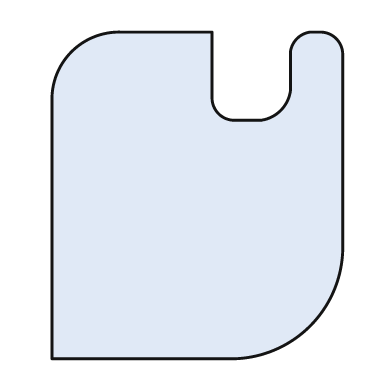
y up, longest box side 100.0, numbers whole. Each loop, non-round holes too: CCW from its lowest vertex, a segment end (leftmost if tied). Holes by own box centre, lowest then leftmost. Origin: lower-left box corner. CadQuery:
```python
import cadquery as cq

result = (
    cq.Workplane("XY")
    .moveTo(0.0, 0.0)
    .lineTo(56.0, 0.0)
    .threePointArc((79.0, 10.0), (89.0, 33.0))
    .lineTo(89.0, 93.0)
    .threePointArc((87.0, 98.0), (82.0, 100.0))
    .lineTo(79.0, 100.0)
    .threePointArc((75.0, 98.0), (73.0, 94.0))
    .lineTo(73.0, 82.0)
    .threePointArc((70.0, 76.0), (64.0, 73.0))
    .lineTo(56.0, 73.0)
    .threePointArc((51.0, 75.0), (49.0, 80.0))
    .lineTo(49.0, 100.0)
    .lineTo(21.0, 100.0)
    .threePointArc((6.0, 94.0), (0.0, 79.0))
    .close()
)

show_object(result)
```